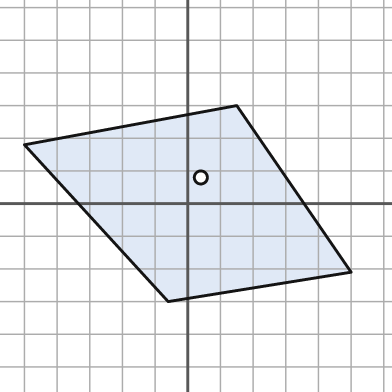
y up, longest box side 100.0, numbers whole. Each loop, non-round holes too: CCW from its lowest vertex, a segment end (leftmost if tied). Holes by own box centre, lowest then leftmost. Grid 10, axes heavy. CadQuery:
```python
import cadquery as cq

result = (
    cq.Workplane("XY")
    .moveTo(-6.0, -30.0)
    .lineTo(50.0, -21.0)
    .lineTo(15.0, 30.0)
    .lineTo(-50.0, 18.0)
    .close()
    .moveTo(4.0, 8.0)
    .circle(2.0)
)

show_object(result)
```